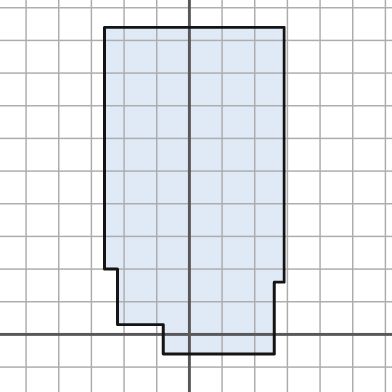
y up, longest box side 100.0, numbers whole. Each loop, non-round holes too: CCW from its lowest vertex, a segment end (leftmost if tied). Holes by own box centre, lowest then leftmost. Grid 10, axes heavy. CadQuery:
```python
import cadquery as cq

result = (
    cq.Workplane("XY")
    .moveTo(-8.0, -6.0)
    .lineTo(26.0, -6.0)
    .lineTo(26.0, 16.0)
    .lineTo(29.0, 16.0)
    .lineTo(29.0, 94.0)
    .lineTo(-26.0, 94.0)
    .lineTo(-26.0, 20.0)
    .lineTo(-22.0, 20.0)
    .lineTo(-22.0, 3.0)
    .lineTo(-8.0, 3.0)
    .close()
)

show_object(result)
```